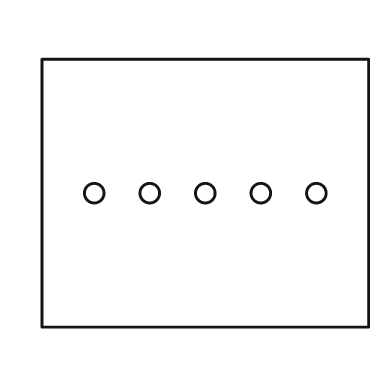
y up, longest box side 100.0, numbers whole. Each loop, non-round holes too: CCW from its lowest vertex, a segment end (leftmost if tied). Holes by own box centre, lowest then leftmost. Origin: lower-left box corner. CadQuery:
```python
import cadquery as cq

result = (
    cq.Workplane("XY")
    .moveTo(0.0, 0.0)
    .lineTo(100.0, 0.0)
    .lineTo(100.0, 82.0)
    .lineTo(0.0, 82.0)
    .close()
    .moveTo(16.0, 41.0)
    .circle(3.0)
    .moveTo(33.0, 41.0)
    .circle(3.0)
    .moveTo(50.0, 41.0)
    .circle(3.0)
    .moveTo(67.0, 41.0)
    .circle(3.0)
    .moveTo(84.0, 41.0)
    .circle(3.0)
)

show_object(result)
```